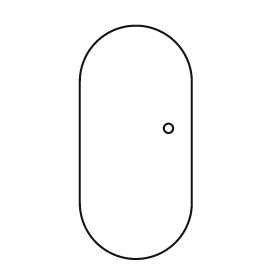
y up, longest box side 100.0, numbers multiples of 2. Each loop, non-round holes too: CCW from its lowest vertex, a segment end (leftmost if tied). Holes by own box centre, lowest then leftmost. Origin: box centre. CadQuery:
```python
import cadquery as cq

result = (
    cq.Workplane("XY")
    .moveTo(-24.0, -26.0)
    .threePointArc((0.0, -50.0), (24.0, -26.0))
    .lineTo(24.0, 26.0)
    .threePointArc((0.0, 50.0), (-24.0, 26.0))
    .close()
    .moveTo(14.0, 6.0)
    .circle(2.0)
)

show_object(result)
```